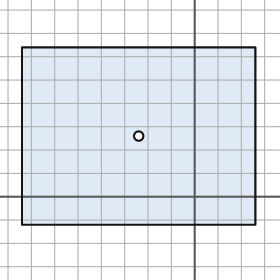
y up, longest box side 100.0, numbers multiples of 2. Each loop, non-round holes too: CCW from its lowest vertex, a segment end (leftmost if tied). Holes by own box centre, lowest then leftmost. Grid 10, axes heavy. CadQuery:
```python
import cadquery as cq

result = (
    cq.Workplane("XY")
    .moveTo(-74.0, -12.0)
    .lineTo(26.0, -12.0)
    .lineTo(26.0, 64.0)
    .lineTo(-74.0, 64.0)
    .close()
    .moveTo(-24.0, 26.0)
    .circle(2.0)
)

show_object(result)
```